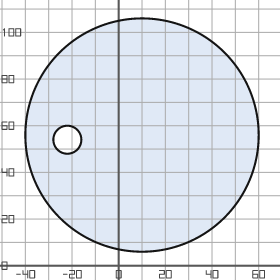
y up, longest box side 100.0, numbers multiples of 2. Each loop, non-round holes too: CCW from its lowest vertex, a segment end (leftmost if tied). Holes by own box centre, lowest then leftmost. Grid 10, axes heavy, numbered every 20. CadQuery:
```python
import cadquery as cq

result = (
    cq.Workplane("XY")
    .moveTo(10.0, 56.0)
    .circle(50.0)
    .moveTo(-22.0, 54.0)
    .circle(6.0)
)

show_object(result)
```